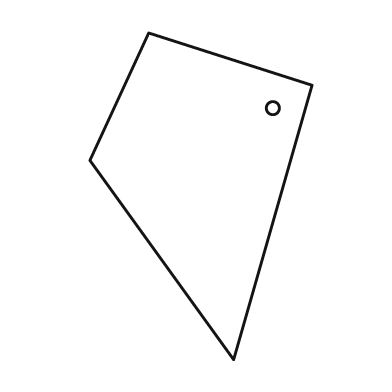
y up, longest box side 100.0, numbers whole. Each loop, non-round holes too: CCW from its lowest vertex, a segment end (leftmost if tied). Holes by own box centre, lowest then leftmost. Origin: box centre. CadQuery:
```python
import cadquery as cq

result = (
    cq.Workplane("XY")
    .moveTo(10.0, -50.0)
    .lineTo(34.0, 34.0)
    .lineTo(-16.0, 50.0)
    .lineTo(-34.0, 11.0)
    .close()
    .moveTo(22.0, 27.0)
    .circle(2.0)
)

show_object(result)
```